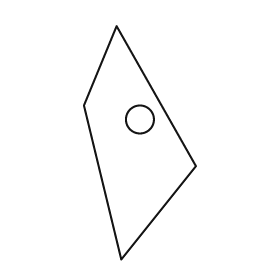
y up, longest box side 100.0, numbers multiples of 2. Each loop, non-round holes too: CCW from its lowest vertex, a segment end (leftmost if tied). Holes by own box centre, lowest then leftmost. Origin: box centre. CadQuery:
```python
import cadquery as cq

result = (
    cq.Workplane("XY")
    .moveTo(-8.0, -50.0)
    .lineTo(24.0, -10.0)
    .lineTo(-10.0, 50.0)
    .lineTo(-24.0, 16.0)
    .close()
    .moveTo(0.0, 10.0)
    .circle(6.0)
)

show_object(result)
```